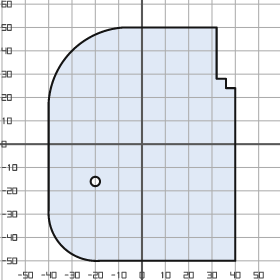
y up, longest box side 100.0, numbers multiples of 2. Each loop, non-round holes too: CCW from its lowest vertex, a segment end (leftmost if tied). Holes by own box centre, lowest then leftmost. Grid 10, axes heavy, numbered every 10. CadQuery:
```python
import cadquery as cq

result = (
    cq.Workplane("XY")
    .moveTo(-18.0, -50.0)
    .lineTo(40.0, -50.0)
    .lineTo(40.0, 24.0)
    .lineTo(36.0, 24.0)
    .lineTo(36.0, 28.0)
    .lineTo(32.0, 28.0)
    .lineTo(32.0, 50.0)
    .lineTo(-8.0, 50.0)
    .threePointArc((-30.0, 40.0), (-40.0, 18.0))
    .lineTo(-40.0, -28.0)
    .threePointArc((-34.0, -44.0), (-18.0, -50.0))
    .close()
    .moveTo(-20.0, -16.0)
    .circle(2.0)
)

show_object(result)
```